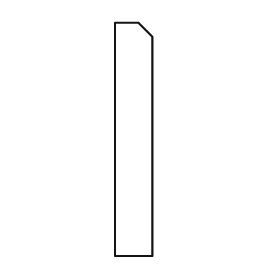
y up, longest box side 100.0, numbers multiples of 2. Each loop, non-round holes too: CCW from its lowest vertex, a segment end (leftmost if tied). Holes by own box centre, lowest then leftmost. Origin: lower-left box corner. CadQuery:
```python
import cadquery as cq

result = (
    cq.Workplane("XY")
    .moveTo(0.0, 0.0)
    .lineTo(16.0, 0.0)
    .lineTo(16.0, 94.0)
    .lineTo(10.0, 100.0)
    .lineTo(0.0, 100.0)
    .close()
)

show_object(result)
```